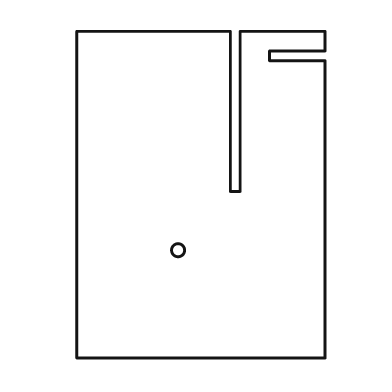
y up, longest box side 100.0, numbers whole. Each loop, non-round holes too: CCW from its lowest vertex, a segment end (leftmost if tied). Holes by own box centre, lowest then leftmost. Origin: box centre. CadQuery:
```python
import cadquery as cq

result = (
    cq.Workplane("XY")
    .moveTo(-38.0, -50.0)
    .lineTo(38.0, -50.0)
    .lineTo(38.0, 41.0)
    .lineTo(21.0, 41.0)
    .lineTo(21.0, 44.0)
    .lineTo(38.0, 44.0)
    .lineTo(38.0, 50.0)
    .lineTo(12.0, 50.0)
    .lineTo(12.0, 1.0)
    .lineTo(9.0, 1.0)
    .lineTo(9.0, 50.0)
    .lineTo(-38.0, 50.0)
    .close()
    .moveTo(-7.0, -17.0)
    .circle(2.0)
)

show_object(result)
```